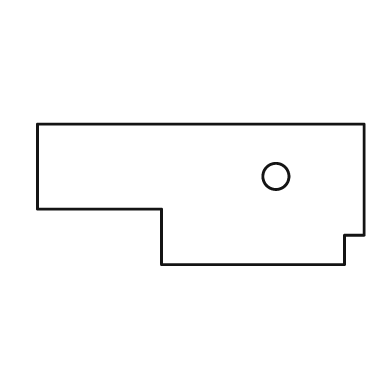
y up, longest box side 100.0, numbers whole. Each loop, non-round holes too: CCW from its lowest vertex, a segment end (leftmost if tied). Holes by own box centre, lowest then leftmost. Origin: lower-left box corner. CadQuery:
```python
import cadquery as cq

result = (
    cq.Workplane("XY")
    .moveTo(38.0, 0.0)
    .lineTo(94.0, 0.0)
    .lineTo(94.0, 9.0)
    .lineTo(100.0, 9.0)
    .lineTo(100.0, 43.0)
    .lineTo(0.0, 43.0)
    .lineTo(0.0, 17.0)
    .lineTo(38.0, 17.0)
    .close()
    .moveTo(73.0, 27.0)
    .circle(4.0)
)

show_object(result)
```